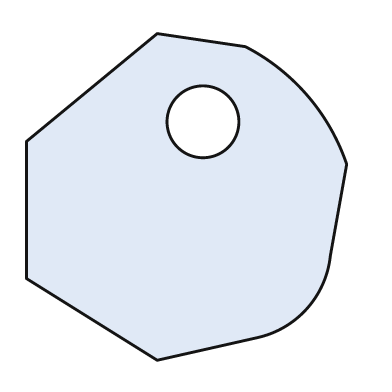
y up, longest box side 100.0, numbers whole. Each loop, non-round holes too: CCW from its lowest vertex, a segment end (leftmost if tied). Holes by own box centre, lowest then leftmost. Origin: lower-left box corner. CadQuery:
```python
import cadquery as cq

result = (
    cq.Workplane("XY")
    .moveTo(40.0, 0.0)
    .lineTo(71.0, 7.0)
    .threePointArc((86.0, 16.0), (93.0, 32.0))
    .lineTo(98.0, 60.0)
    .threePointArc((86.0, 81.0), (67.0, 96.0))
    .lineTo(40.0, 100.0)
    .lineTo(0.0, 67.0)
    .lineTo(0.0, 25.0)
    .close()
    .moveTo(54.0, 73.0)
    .circle(11.0)
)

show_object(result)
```